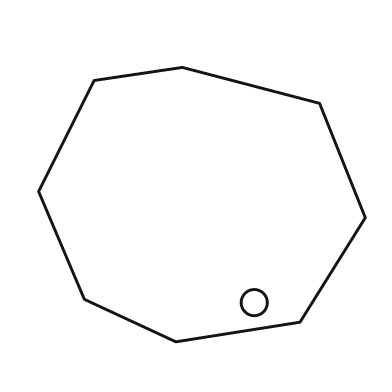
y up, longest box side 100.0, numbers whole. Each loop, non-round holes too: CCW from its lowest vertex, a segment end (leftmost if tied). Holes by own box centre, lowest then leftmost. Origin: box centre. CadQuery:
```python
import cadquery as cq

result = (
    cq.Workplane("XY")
    .moveTo(-8.0, -42.0)
    .lineTo(30.0, -36.0)
    .lineTo(50.0, -4.0)
    .lineTo(36.0, 31.0)
    .lineTo(-6.0, 42.0)
    .lineTo(-33.0, 38.0)
    .lineTo(-50.0, 4.0)
    .lineTo(-36.0, -29.0)
    .close()
    .moveTo(16.0, -30.0)
    .circle(4.0)
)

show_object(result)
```